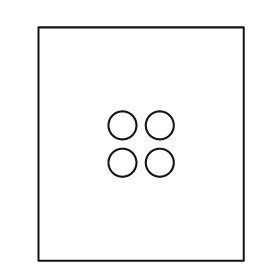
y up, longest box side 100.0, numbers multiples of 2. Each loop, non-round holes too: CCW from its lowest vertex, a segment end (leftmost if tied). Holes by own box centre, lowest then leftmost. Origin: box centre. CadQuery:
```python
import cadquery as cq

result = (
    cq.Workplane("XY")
    .moveTo(-44.0, -50.0)
    .lineTo(44.0, -50.0)
    .lineTo(44.0, 50.0)
    .lineTo(-44.0, 50.0)
    .close()
    .moveTo(-8.0, -8.0)
    .circle(6.0)
    .moveTo(8.0, -8.0)
    .circle(6.0)
    .moveTo(-8.0, 8.0)
    .circle(6.0)
    .moveTo(8.0, 8.0)
    .circle(6.0)
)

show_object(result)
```